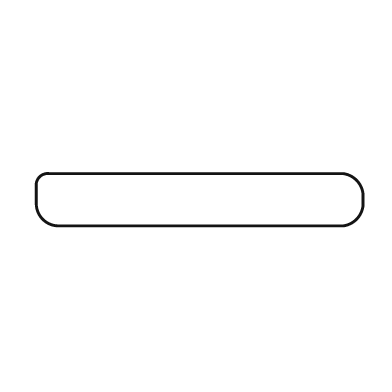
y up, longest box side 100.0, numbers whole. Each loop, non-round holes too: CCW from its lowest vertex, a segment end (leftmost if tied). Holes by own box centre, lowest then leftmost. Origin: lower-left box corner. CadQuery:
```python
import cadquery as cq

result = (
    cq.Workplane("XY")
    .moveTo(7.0, 0.0)
    .lineTo(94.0, 0.0)
    .threePointArc((98.0, 2.0), (100.0, 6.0))
    .lineTo(100.0, 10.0)
    .threePointArc((98.0, 14.0), (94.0, 16.0))
    .lineTo(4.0, 16.0)
    .threePointArc((1.0, 15.0), (0.0, 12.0))
    .lineTo(0.0, 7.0)
    .threePointArc((2.0, 2.0), (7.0, 0.0))
    .close()
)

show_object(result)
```